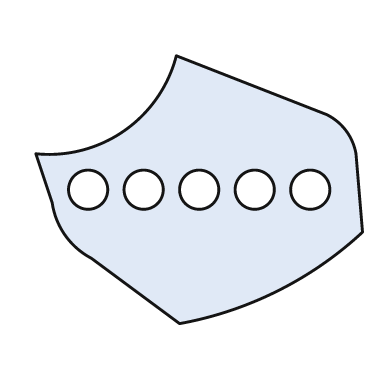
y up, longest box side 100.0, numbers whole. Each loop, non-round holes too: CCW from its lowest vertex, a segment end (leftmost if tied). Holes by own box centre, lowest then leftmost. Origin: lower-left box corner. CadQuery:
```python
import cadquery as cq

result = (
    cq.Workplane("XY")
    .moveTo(44.0, 0.0)
    .threePointArc((74.0, 10.0), (100.0, 28.0))
    .lineTo(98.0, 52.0)
    .threePointArc((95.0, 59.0), (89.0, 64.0))
    .lineTo(43.0, 82.0)
    .threePointArc((27.0, 59.0), (0.0, 52.0))
    .lineTo(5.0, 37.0)
    .threePointArc((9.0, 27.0), (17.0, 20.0))
    .close()
    .moveTo(16.0, 41.0)
    .circle(6.0)
    .moveTo(33.0, 41.0)
    .circle(6.0)
    .moveTo(50.0, 41.0)
    .circle(6.0)
    .moveTo(67.0, 41.0)
    .circle(6.0)
    .moveTo(84.0, 41.0)
    .circle(6.0)
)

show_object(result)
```